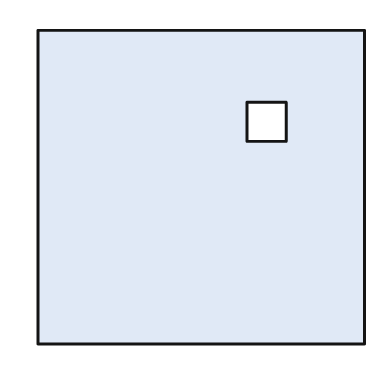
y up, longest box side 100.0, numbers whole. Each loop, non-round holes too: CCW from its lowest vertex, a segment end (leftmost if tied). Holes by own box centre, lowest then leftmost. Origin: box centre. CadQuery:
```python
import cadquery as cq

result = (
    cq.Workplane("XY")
    .moveTo(-50.0, -48.0)
    .lineTo(50.0, -48.0)
    .lineTo(50.0, 48.0)
    .lineTo(-50.0, 48.0)
    .close()
    .moveTo(14.0, 14.0)
    .lineTo(26.0, 14.0)
    .lineTo(26.0, 26.0)
    .lineTo(14.0, 26.0)
    .close()
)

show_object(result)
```